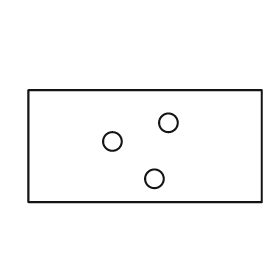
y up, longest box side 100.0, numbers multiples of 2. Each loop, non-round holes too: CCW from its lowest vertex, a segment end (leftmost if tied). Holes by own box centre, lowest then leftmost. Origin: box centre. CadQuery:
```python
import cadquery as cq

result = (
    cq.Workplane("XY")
    .moveTo(-50.0, -24.0)
    .lineTo(50.0, -24.0)
    .lineTo(50.0, 24.0)
    .lineTo(-50.0, 24.0)
    .close()
    .moveTo(4.0, -14.0)
    .circle(4.0)
    .moveTo(-14.0, 2.0)
    .circle(4.0)
    .moveTo(10.0, 10.0)
    .circle(4.0)
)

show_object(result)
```